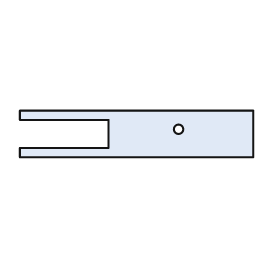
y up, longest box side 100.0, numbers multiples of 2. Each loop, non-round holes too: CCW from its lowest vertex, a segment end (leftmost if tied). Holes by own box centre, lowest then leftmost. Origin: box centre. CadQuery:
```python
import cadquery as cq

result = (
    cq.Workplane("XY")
    .moveTo(-50.0, -10.0)
    .lineTo(50.0, -10.0)
    .lineTo(50.0, 10.0)
    .lineTo(-50.0, 10.0)
    .lineTo(-50.0, 6.0)
    .lineTo(-12.0, 6.0)
    .lineTo(-12.0, -6.0)
    .lineTo(-50.0, -6.0)
    .close()
    .moveTo(18.0, 2.0)
    .circle(2.0)
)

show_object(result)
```